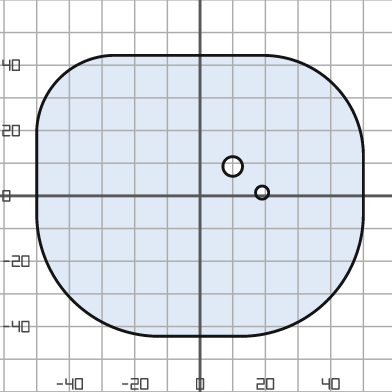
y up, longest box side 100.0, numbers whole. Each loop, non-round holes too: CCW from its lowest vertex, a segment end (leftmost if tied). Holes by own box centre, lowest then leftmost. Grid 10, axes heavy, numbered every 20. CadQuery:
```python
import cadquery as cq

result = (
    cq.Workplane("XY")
    .moveTo(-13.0, -43.0)
    .lineTo(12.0, -43.0)
    .threePointArc((39.0, -32.0), (50.0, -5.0))
    .lineTo(50.0, 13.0)
    .threePointArc((41.0, 34.0), (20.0, 43.0))
    .lineTo(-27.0, 43.0)
    .threePointArc((-43.0, 36.0), (-50.0, 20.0))
    .lineTo(-50.0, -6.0)
    .threePointArc((-39.0, -32.0), (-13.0, -43.0))
    .close()
    .moveTo(19.0, 1.0)
    .circle(2.0)
    .moveTo(10.0, 9.0)
    .circle(3.0)
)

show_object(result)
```